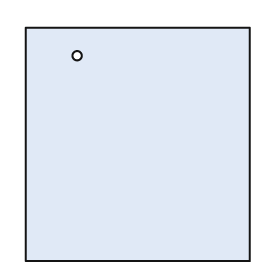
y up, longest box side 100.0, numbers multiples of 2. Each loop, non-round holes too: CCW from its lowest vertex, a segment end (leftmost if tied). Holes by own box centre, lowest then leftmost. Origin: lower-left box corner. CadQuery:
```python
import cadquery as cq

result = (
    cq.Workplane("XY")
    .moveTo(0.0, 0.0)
    .lineTo(96.0, 0.0)
    .lineTo(96.0, 100.0)
    .lineTo(0.0, 100.0)
    .close()
    .moveTo(22.0, 88.0)
    .circle(2.0)
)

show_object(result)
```